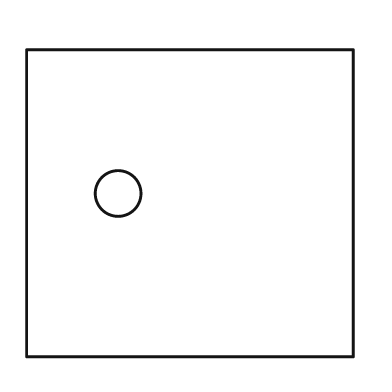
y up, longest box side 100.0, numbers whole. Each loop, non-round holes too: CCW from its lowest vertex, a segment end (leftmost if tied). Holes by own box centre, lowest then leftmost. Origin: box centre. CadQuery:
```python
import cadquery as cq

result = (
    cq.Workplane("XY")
    .moveTo(-50.0, -47.0)
    .lineTo(50.0, -47.0)
    .lineTo(50.0, 47.0)
    .lineTo(-50.0, 47.0)
    .close()
    .moveTo(-22.0, 3.0)
    .circle(7.0)
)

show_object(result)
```